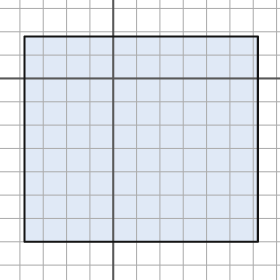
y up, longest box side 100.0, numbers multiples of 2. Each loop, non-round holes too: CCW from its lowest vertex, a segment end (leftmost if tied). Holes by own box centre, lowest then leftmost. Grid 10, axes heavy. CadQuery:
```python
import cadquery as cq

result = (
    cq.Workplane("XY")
    .moveTo(-38.0, -70.0)
    .lineTo(62.0, -70.0)
    .lineTo(62.0, 18.0)
    .lineTo(-38.0, 18.0)
    .close()
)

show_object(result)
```